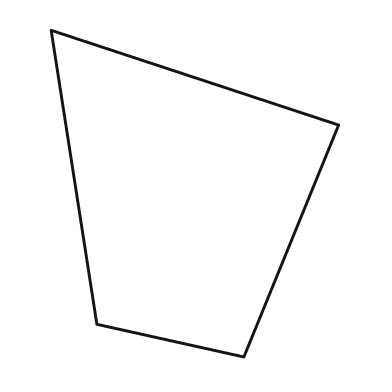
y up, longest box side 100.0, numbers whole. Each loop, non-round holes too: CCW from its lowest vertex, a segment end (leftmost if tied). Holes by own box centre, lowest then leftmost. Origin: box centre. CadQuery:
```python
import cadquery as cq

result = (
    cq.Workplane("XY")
    .moveTo(15.0, -50.0)
    .lineTo(44.0, 21.0)
    .lineTo(-44.0, 50.0)
    .lineTo(-30.0, -40.0)
    .close()
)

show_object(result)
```